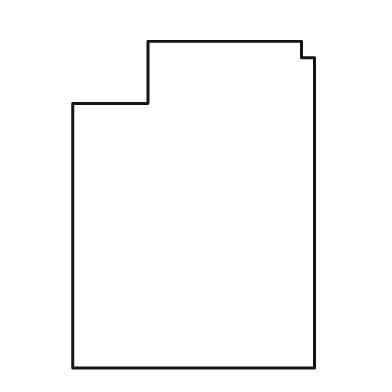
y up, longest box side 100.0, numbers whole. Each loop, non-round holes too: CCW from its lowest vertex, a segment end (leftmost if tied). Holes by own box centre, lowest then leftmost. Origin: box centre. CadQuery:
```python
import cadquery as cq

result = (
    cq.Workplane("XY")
    .moveTo(-37.0, -50.0)
    .lineTo(37.0, -50.0)
    .lineTo(37.0, 45.0)
    .lineTo(33.0, 45.0)
    .lineTo(33.0, 50.0)
    .lineTo(-14.0, 50.0)
    .lineTo(-14.0, 31.0)
    .lineTo(-37.0, 31.0)
    .close()
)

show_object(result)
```